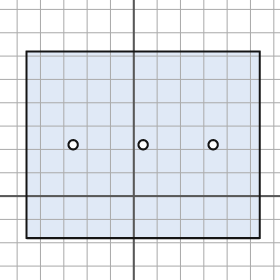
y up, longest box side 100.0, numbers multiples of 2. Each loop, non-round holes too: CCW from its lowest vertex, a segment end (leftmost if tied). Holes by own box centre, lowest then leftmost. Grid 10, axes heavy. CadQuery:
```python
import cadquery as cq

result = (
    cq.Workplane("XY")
    .moveTo(-46.0, -18.0)
    .lineTo(54.0, -18.0)
    .lineTo(54.0, 62.0)
    .lineTo(-46.0, 62.0)
    .close()
    .moveTo(-26.0, 22.0)
    .circle(2.0)
    .moveTo(4.0, 22.0)
    .circle(2.0)
    .moveTo(34.0, 22.0)
    .circle(2.0)
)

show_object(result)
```